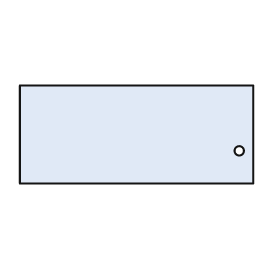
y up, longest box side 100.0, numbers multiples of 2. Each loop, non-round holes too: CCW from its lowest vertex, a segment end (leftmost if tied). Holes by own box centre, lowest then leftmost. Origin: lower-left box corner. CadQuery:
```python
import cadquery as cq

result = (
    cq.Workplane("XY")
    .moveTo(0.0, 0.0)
    .lineTo(100.0, 0.0)
    .lineTo(100.0, 42.0)
    .lineTo(0.0, 42.0)
    .close()
    .moveTo(94.0, 14.0)
    .circle(2.0)
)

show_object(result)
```